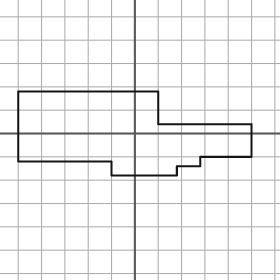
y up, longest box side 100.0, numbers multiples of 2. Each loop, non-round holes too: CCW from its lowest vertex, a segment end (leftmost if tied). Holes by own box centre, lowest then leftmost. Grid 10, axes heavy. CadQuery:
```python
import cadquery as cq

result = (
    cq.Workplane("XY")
    .moveTo(-10.0, -18.0)
    .lineTo(18.0, -18.0)
    .lineTo(18.0, -14.0)
    .lineTo(28.0, -14.0)
    .lineTo(28.0, -10.0)
    .lineTo(50.0, -10.0)
    .lineTo(50.0, 4.0)
    .lineTo(10.0, 4.0)
    .lineTo(10.0, 18.0)
    .lineTo(-50.0, 18.0)
    .lineTo(-50.0, -12.0)
    .lineTo(-10.0, -12.0)
    .close()
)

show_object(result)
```